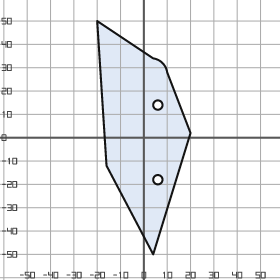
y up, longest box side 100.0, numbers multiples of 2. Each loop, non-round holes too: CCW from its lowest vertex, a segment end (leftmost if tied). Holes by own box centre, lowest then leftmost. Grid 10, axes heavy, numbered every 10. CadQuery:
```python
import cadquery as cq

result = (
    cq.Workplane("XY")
    .moveTo(4.0, -50.0)
    .lineTo(20.0, 2.0)
    .lineTo(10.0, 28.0)
    .threePointArc((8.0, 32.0), (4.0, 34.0))
    .lineTo(-20.0, 50.0)
    .lineTo(-16.0, -12.0)
    .close()
    .moveTo(6.0, -18.0)
    .circle(2.0)
    .moveTo(6.0, 14.0)
    .circle(2.0)
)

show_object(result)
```